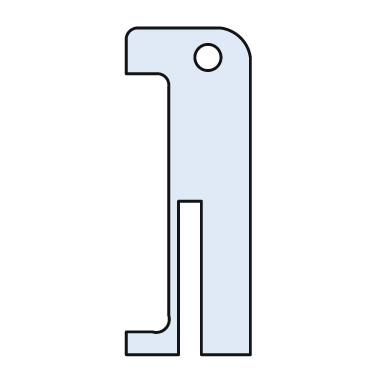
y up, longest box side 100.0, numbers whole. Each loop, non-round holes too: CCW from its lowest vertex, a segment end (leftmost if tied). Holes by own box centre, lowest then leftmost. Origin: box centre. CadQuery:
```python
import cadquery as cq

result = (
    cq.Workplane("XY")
    .moveTo(-19.0, -50.0)
    .lineTo(-3.0, -50.0)
    .lineTo(-3.0, -3.0)
    .lineTo(4.0, -3.0)
    .lineTo(4.0, -50.0)
    .lineTo(19.0, -50.0)
    .lineTo(19.0, 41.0)
    .threePointArc((16.0, 47.0), (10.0, 50.0))
    .lineTo(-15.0, 50.0)
    .threePointArc((-18.0, 49.0), (-19.0, 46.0))
    .lineTo(-19.0, 36.0)
    .lineTo(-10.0, 36.0)
    .threePointArc((-7.0, 35.0), (-6.0, 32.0))
    .lineTo(-6.0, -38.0)
    .threePointArc((-7.0, -42.0), (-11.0, -43.0))
    .lineTo(-19.0, -43.0)
    .close()
    .moveTo(6.0, 41.0)
    .circle(4.0)
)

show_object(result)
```